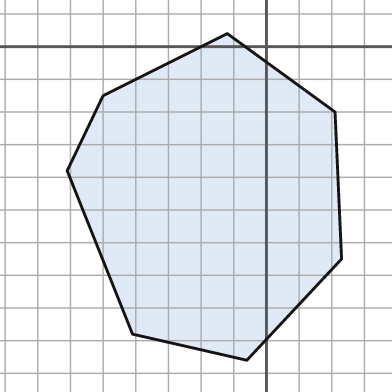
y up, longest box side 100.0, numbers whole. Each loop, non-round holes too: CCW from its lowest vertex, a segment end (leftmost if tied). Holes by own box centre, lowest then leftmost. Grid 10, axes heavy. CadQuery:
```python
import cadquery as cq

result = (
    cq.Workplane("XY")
    .moveTo(-6.0, -96.0)
    .lineTo(23.0, -65.0)
    .lineTo(21.0, -20.0)
    .lineTo(-12.0, 4.0)
    .lineTo(-50.0, -15.0)
    .lineTo(-61.0, -38.0)
    .lineTo(-41.0, -88.0)
    .close()
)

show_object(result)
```